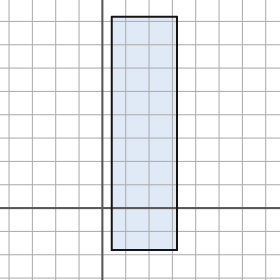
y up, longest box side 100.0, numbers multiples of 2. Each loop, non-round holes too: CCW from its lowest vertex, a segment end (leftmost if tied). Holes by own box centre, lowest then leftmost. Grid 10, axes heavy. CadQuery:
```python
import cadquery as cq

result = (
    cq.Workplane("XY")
    .moveTo(4.0, -18.0)
    .lineTo(32.0, -18.0)
    .lineTo(32.0, 82.0)
    .lineTo(4.0, 82.0)
    .close()
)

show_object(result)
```